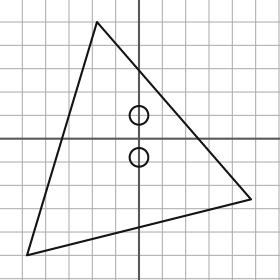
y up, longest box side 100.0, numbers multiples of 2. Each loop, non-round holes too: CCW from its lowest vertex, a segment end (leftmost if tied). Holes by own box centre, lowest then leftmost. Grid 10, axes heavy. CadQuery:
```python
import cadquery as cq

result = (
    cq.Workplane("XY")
    .moveTo(-48.0, -50.0)
    .lineTo(48.0, -26.0)
    .lineTo(-18.0, 50.0)
    .close()
    .moveTo(0.0, -8.0)
    .circle(4.0)
    .moveTo(0.0, 10.0)
    .circle(4.0)
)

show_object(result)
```